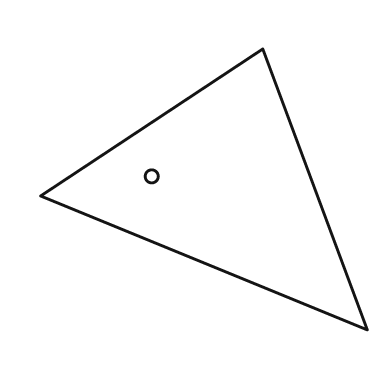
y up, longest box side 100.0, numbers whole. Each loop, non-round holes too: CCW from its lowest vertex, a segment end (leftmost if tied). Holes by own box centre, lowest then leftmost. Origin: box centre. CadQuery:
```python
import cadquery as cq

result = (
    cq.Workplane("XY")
    .moveTo(50.0, -43.0)
    .lineTo(18.0, 43.0)
    .lineTo(-50.0, -2.0)
    .close()
    .moveTo(-16.0, 4.0)
    .circle(2.0)
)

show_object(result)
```